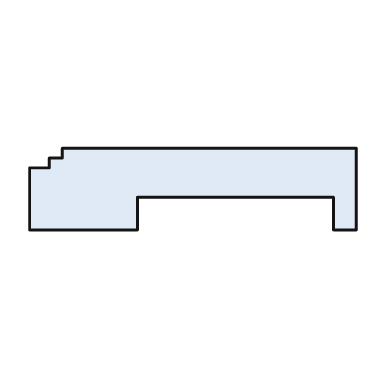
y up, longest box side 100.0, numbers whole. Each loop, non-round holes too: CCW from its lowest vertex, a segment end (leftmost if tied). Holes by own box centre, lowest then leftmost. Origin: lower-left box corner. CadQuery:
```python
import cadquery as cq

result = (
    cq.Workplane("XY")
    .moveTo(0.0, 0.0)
    .lineTo(33.0, 0.0)
    .lineTo(33.0, 10.0)
    .lineTo(93.0, 10.0)
    .lineTo(93.0, 0.0)
    .lineTo(100.0, 0.0)
    .lineTo(100.0, 25.0)
    .lineTo(10.0, 25.0)
    .lineTo(10.0, 22.0)
    .lineTo(6.0, 22.0)
    .lineTo(6.0, 19.0)
    .lineTo(0.0, 19.0)
    .close()
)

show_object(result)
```